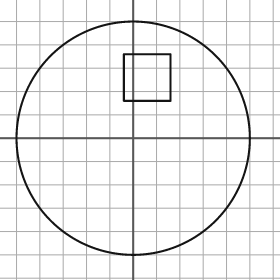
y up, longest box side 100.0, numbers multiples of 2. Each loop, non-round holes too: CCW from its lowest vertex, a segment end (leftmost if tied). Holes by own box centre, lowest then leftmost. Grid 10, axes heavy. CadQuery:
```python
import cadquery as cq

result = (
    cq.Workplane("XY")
    .moveTo(0.0, 0.0)
    .circle(50.0)
    .moveTo(-4.0, 16.0)
    .lineTo(16.0, 16.0)
    .lineTo(16.0, 36.0)
    .lineTo(-4.0, 36.0)
    .close()
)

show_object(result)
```